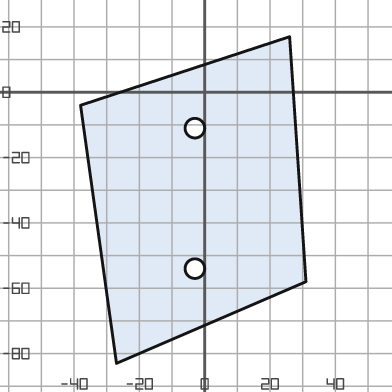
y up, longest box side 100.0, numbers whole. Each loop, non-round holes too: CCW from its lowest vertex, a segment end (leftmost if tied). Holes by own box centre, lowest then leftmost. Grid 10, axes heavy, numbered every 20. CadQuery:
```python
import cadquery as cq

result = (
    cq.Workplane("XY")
    .moveTo(-27.0, -83.0)
    .lineTo(31.0, -58.0)
    .lineTo(26.0, 17.0)
    .lineTo(-38.0, -4.0)
    .close()
    .moveTo(-3.0, -54.0)
    .circle(3.0)
    .moveTo(-3.0, -11.0)
    .circle(3.0)
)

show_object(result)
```